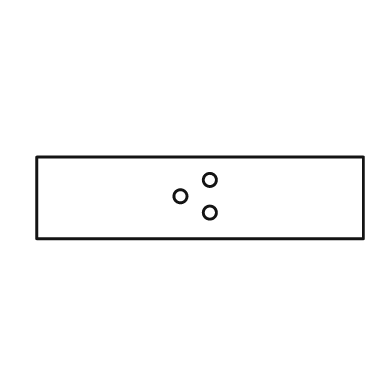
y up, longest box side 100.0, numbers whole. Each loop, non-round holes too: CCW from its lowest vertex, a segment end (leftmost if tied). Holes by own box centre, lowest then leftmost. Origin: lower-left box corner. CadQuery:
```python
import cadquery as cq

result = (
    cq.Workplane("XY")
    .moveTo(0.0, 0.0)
    .lineTo(100.0, 0.0)
    .lineTo(100.0, 25.0)
    .lineTo(0.0, 25.0)
    .close()
    .moveTo(53.0, 8.0)
    .circle(2.0)
    .moveTo(44.0, 13.0)
    .circle(2.0)
    .moveTo(53.0, 18.0)
    .circle(2.0)
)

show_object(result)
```